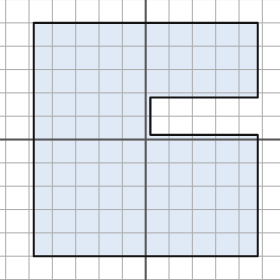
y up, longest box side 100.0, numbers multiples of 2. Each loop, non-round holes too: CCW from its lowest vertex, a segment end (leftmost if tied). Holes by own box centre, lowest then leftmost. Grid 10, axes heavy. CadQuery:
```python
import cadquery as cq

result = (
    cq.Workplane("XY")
    .moveTo(-48.0, -50.0)
    .lineTo(48.0, -50.0)
    .lineTo(48.0, 2.0)
    .lineTo(2.0, 2.0)
    .lineTo(2.0, 18.0)
    .lineTo(48.0, 18.0)
    .lineTo(48.0, 50.0)
    .lineTo(-48.0, 50.0)
    .close()
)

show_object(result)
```